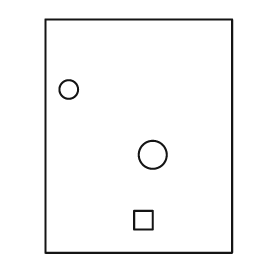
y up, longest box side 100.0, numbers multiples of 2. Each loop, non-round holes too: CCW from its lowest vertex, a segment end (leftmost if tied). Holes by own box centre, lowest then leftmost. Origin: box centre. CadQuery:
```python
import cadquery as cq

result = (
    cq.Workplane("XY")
    .moveTo(-40.0, -50.0)
    .lineTo(40.0, -50.0)
    .lineTo(40.0, 50.0)
    .lineTo(-40.0, 50.0)
    .close()
    .moveTo(-2.0, -40.0)
    .lineTo(6.0, -40.0)
    .lineTo(6.0, -32.0)
    .lineTo(-2.0, -32.0)
    .close()
    .moveTo(6.0, -8.0)
    .circle(6.0)
    .moveTo(-30.0, 20.0)
    .circle(4.0)
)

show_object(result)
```